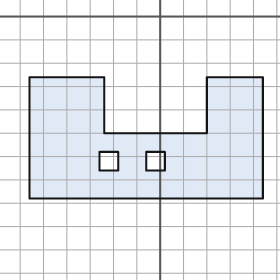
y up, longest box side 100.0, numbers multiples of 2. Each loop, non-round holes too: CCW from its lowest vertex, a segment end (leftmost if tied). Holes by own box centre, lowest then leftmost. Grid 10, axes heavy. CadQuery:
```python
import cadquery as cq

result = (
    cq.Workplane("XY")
    .moveTo(-56.0, -78.0)
    .lineTo(44.0, -78.0)
    .lineTo(44.0, -26.0)
    .lineTo(20.0, -26.0)
    .lineTo(20.0, -50.0)
    .lineTo(-24.0, -50.0)
    .lineTo(-24.0, -26.0)
    .lineTo(-56.0, -26.0)
    .close()
    .moveTo(-26.0, -66.0)
    .lineTo(-18.0, -66.0)
    .lineTo(-18.0, -58.0)
    .lineTo(-26.0, -58.0)
    .close()
    .moveTo(-6.0, -66.0)
    .lineTo(2.0, -66.0)
    .lineTo(2.0, -58.0)
    .lineTo(-6.0, -58.0)
    .close()
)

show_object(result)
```